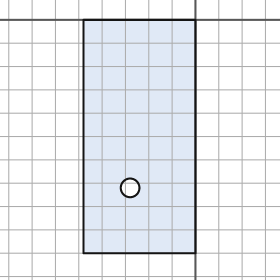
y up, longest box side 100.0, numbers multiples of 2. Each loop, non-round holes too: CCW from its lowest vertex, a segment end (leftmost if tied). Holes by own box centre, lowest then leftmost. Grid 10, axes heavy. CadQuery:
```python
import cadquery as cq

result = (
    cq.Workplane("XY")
    .moveTo(-48.0, -100.0)
    .lineTo(0.0, -100.0)
    .lineTo(0.0, 0.0)
    .lineTo(-48.0, 0.0)
    .close()
    .moveTo(-28.0, -72.0)
    .circle(4.0)
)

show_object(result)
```